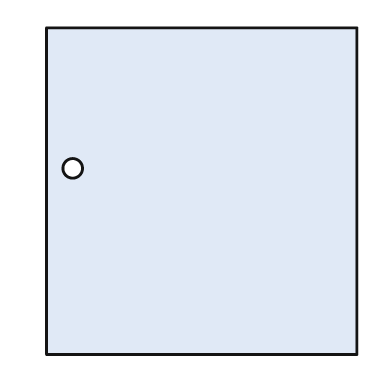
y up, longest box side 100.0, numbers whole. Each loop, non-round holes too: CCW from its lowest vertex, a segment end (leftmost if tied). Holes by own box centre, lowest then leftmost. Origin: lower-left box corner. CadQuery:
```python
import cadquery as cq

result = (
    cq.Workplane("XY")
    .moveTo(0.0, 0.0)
    .lineTo(95.0, 0.0)
    .lineTo(95.0, 100.0)
    .lineTo(0.0, 100.0)
    .close()
    .moveTo(8.0, 57.0)
    .circle(3.0)
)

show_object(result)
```